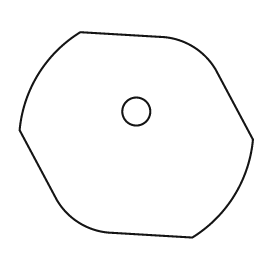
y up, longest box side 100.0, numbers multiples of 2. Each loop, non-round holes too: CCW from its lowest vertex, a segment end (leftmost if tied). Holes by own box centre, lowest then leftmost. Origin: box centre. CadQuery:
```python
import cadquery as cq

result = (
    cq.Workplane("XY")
    .moveTo(24.0, -44.0)
    .threePointArc((42.0, -26.0), (50.0, -2.0))
    .lineTo(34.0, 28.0)
    .threePointArc((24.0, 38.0), (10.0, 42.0))
    .lineTo(-24.0, 44.0)
    .threePointArc((-42.0, 26.0), (-50.0, 2.0))
    .lineTo(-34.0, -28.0)
    .threePointArc((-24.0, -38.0), (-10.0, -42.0))
    .close()
    .moveTo(0.0, 10.0)
    .circle(6.0)
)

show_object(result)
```